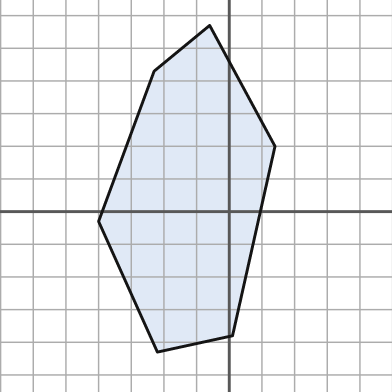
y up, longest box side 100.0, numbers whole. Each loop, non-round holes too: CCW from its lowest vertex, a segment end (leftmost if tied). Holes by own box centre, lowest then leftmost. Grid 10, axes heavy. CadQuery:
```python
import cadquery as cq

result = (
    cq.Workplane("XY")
    .moveTo(-22.0, -43.0)
    .lineTo(1.0, -38.0)
    .lineTo(14.0, 20.0)
    .lineTo(-6.0, 57.0)
    .lineTo(-23.0, 43.0)
    .lineTo(-40.0, -3.0)
    .close()
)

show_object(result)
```